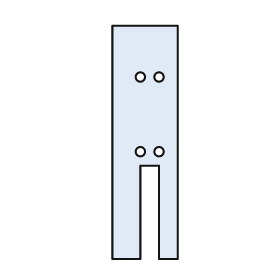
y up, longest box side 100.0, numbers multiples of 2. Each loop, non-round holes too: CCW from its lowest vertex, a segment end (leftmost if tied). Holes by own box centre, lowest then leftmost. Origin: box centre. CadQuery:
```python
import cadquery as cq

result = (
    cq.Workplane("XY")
    .moveTo(-14.0, -50.0)
    .lineTo(-2.0, -50.0)
    .lineTo(-2.0, -10.0)
    .lineTo(6.0, -10.0)
    .lineTo(6.0, -50.0)
    .lineTo(14.0, -50.0)
    .lineTo(14.0, 50.0)
    .lineTo(-14.0, 50.0)
    .close()
    .moveTo(-2.0, -4.0)
    .circle(2.0)
    .moveTo(6.0, -4.0)
    .circle(2.0)
    .moveTo(-2.0, 28.0)
    .circle(2.0)
    .moveTo(6.0, 28.0)
    .circle(2.0)
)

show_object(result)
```